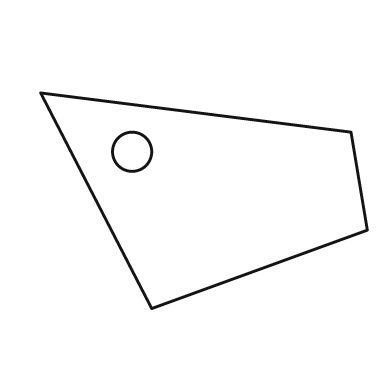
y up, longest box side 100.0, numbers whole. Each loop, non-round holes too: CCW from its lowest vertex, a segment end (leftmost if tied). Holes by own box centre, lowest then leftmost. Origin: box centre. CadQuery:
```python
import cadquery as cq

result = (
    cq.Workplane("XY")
    .moveTo(-16.0, -33.0)
    .lineTo(50.0, -9.0)
    .lineTo(45.0, 21.0)
    .lineTo(-50.0, 33.0)
    .close()
    .moveTo(-22.0, 15.0)
    .circle(6.0)
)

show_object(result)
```